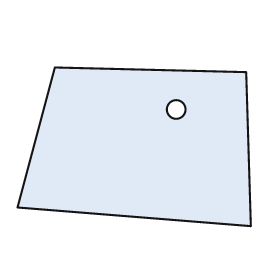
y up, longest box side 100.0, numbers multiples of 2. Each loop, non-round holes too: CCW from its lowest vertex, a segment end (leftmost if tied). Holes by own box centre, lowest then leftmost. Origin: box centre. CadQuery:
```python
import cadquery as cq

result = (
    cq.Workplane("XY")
    .moveTo(50.0, -34.0)
    .lineTo(48.0, 32.0)
    .lineTo(-34.0, 34.0)
    .lineTo(-50.0, -26.0)
    .close()
    .moveTo(18.0, 16.0)
    .circle(4.0)
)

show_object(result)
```